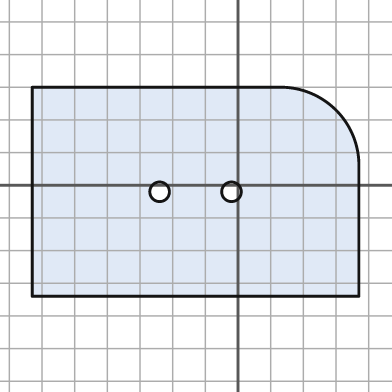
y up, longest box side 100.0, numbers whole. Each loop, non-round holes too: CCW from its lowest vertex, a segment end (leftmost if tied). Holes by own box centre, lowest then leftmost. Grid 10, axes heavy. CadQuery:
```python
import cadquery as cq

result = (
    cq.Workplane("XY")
    .moveTo(-63.0, -34.0)
    .lineTo(37.0, -34.0)
    .lineTo(37.0, 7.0)
    .threePointArc((30.0, 23.0), (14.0, 30.0))
    .lineTo(-63.0, 30.0)
    .close()
    .moveTo(-24.0, -2.0)
    .circle(3.0)
    .moveTo(-2.0, -2.0)
    .circle(3.0)
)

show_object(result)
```